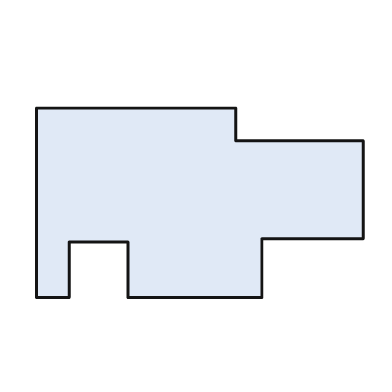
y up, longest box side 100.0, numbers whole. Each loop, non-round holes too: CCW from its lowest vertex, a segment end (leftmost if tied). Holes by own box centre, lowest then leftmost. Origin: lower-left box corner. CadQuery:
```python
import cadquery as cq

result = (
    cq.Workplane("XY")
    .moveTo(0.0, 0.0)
    .lineTo(10.0, 0.0)
    .lineTo(10.0, 17.0)
    .lineTo(28.0, 17.0)
    .lineTo(28.0, 0.0)
    .lineTo(69.0, 0.0)
    .lineTo(69.0, 18.0)
    .lineTo(100.0, 18.0)
    .lineTo(100.0, 48.0)
    .lineTo(61.0, 48.0)
    .lineTo(61.0, 58.0)
    .lineTo(0.0, 58.0)
    .close()
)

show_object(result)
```